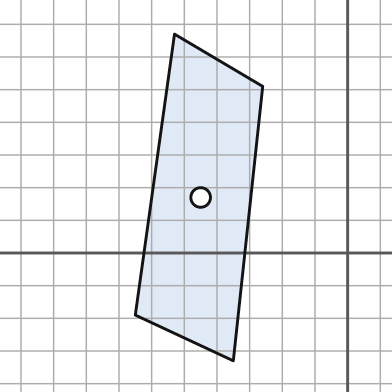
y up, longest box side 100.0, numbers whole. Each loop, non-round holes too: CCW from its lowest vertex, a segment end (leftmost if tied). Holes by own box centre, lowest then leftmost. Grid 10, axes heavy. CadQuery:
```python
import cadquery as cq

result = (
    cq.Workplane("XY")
    .moveTo(-35.0, -33.0)
    .lineTo(-26.0, 51.0)
    .lineTo(-53.0, 67.0)
    .lineTo(-65.0, -19.0)
    .close()
    .moveTo(-45.0, 17.0)
    .circle(3.0)
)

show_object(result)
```